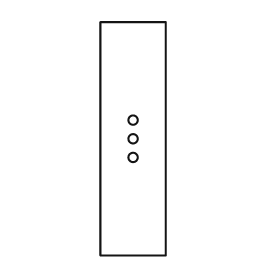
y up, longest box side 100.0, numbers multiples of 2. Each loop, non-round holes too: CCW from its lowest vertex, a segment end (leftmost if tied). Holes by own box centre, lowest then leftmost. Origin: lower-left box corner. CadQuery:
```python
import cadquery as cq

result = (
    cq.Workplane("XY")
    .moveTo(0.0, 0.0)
    .lineTo(28.0, 0.0)
    .lineTo(28.0, 100.0)
    .lineTo(0.0, 100.0)
    .close()
    .moveTo(14.0, 42.0)
    .circle(2.0)
    .moveTo(14.0, 50.0)
    .circle(2.0)
    .moveTo(14.0, 58.0)
    .circle(2.0)
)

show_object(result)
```